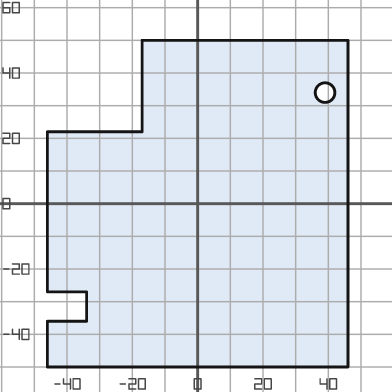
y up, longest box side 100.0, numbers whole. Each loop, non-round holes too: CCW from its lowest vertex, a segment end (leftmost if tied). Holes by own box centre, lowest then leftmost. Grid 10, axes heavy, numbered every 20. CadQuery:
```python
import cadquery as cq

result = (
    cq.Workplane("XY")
    .moveTo(-46.0, -50.0)
    .lineTo(46.0, -50.0)
    .lineTo(46.0, 50.0)
    .lineTo(-17.0, 50.0)
    .lineTo(-17.0, 22.0)
    .lineTo(-46.0, 22.0)
    .lineTo(-46.0, -27.0)
    .lineTo(-34.0, -27.0)
    .lineTo(-34.0, -36.0)
    .lineTo(-46.0, -36.0)
    .close()
    .moveTo(39.0, 34.0)
    .circle(3.0)
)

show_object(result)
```